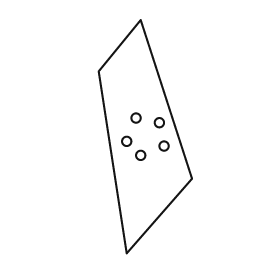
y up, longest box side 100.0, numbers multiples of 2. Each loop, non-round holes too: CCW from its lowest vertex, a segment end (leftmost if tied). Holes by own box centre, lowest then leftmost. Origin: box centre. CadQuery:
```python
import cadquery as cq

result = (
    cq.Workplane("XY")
    .moveTo(-8.0, -50.0)
    .lineTo(20.0, -18.0)
    .lineTo(-2.0, 50.0)
    .lineTo(-20.0, 28.0)
    .close()
    .moveTo(-2.0, -8.0)
    .circle(2.0)
    .moveTo(8.0, -4.0)
    .circle(2.0)
    .moveTo(-8.0, -2.0)
    .circle(2.0)
    .moveTo(6.0, 6.0)
    .circle(2.0)
    .moveTo(-4.0, 8.0)
    .circle(2.0)
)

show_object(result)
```